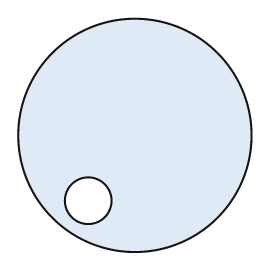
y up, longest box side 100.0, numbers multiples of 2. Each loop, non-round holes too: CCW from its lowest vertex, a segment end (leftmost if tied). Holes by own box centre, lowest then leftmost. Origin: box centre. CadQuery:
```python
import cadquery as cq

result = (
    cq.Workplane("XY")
    .moveTo(0.0, 0.0)
    .circle(50.0)
    .moveTo(-20.0, -28.0)
    .circle(10.0)
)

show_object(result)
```